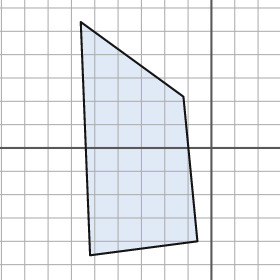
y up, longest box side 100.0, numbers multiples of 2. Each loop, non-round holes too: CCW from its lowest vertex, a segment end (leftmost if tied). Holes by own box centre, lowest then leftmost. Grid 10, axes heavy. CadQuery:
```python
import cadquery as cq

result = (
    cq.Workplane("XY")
    .moveTo(-52.0, -46.0)
    .lineTo(-6.0, -40.0)
    .lineTo(-12.0, 22.0)
    .lineTo(-56.0, 54.0)
    .close()
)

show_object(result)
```